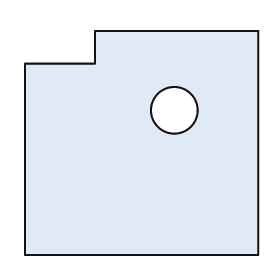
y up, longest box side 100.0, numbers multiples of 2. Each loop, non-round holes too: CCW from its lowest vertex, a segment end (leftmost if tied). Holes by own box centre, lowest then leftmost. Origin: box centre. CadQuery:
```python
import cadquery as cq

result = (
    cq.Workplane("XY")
    .moveTo(-50.0, -48.0)
    .lineTo(50.0, -48.0)
    .lineTo(50.0, 48.0)
    .lineTo(-20.0, 48.0)
    .lineTo(-20.0, 34.0)
    .lineTo(-50.0, 34.0)
    .close()
    .moveTo(14.0, 14.0)
    .circle(10.0)
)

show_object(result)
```